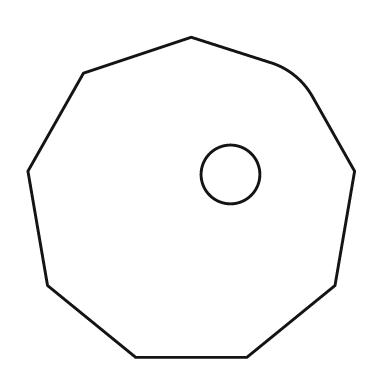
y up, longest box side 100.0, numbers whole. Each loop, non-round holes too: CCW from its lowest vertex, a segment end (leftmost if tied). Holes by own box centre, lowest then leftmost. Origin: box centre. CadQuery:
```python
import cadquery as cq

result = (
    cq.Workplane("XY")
    .moveTo(-17.0, -49.0)
    .lineTo(17.0, -49.0)
    .lineTo(44.0, -27.0)
    .lineTo(50.0, 8.0)
    .lineTo(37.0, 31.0)
    .threePointArc((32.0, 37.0), (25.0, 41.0))
    .lineTo(0.0, 49.0)
    .lineTo(-33.0, 38.0)
    .lineTo(-50.0, 8.0)
    .lineTo(-44.0, -27.0)
    .close()
    .moveTo(12.0, 7.0)
    .circle(9.0)
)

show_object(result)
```